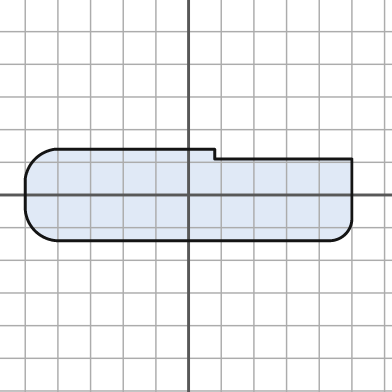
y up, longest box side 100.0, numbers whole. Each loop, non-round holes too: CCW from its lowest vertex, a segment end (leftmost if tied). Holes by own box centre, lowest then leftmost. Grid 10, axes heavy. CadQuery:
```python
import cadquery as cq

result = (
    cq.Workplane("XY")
    .moveTo(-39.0, -14.0)
    .lineTo(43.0, -14.0)
    .threePointArc((48.0, -12.0), (50.0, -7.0))
    .lineTo(50.0, 11.0)
    .lineTo(8.0, 11.0)
    .lineTo(8.0, 14.0)
    .lineTo(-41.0, 14.0)
    .threePointArc((-47.0, 11.0), (-50.0, 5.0))
    .lineTo(-50.0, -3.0)
    .threePointArc((-47.0, -11.0), (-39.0, -14.0))
    .close()
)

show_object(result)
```